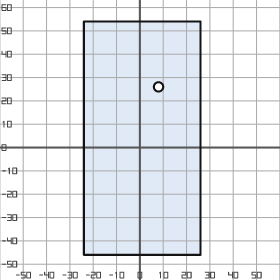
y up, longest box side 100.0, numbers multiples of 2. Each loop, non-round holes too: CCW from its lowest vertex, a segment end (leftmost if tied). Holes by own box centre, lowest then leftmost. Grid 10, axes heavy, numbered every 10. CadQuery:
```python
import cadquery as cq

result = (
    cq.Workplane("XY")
    .moveTo(-24.0, -46.0)
    .lineTo(26.0, -46.0)
    .lineTo(26.0, 54.0)
    .lineTo(-24.0, 54.0)
    .close()
    .moveTo(8.0, 26.0)
    .circle(2.0)
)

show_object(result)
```